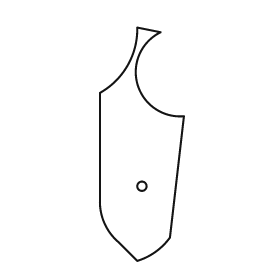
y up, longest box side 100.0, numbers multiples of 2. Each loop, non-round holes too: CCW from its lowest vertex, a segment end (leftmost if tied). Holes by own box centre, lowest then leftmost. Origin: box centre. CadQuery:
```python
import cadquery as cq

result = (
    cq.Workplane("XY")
    .moveTo(-2.0, -50.0)
    .threePointArc((6.0, -46.0), (12.0, -40.0))
    .lineTo(18.0, 12.0)
    .threePointArc((-2.0, 26.0), (8.0, 48.0))
    .lineTo(-2.0, 50.0)
    .threePointArc((-6.0, 34.0), (-18.0, 22.0))
    .lineTo(-18.0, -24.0)
    .threePointArc((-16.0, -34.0), (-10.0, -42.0))
    .close()
    .moveTo(0.0, -18.0)
    .circle(2.0)
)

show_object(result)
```